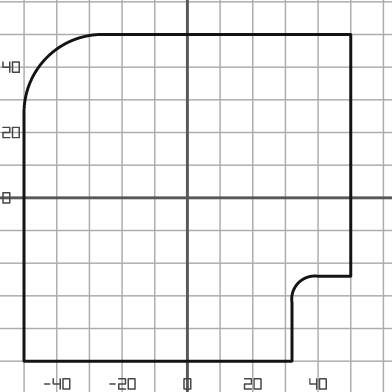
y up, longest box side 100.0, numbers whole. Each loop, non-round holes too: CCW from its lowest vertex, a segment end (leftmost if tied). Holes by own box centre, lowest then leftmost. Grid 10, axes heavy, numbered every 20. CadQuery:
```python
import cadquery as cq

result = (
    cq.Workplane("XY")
    .moveTo(-50.0, -50.0)
    .lineTo(32.0, -50.0)
    .lineTo(32.0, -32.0)
    .threePointArc((34.0, -26.0), (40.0, -24.0))
    .lineTo(50.0, -24.0)
    .lineTo(50.0, 50.0)
    .lineTo(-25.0, 50.0)
    .threePointArc((-43.0, 43.0), (-50.0, 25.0))
    .close()
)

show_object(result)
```